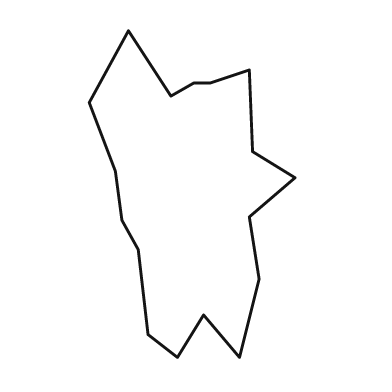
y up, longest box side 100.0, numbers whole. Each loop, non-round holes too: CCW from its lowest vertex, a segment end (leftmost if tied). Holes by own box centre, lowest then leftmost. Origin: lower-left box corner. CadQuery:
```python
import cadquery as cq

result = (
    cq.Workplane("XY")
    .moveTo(27.0, 0.0)
    .lineTo(35.0, 13.0)
    .lineTo(46.0, 0.0)
    .lineTo(52.0, 24.0)
    .lineTo(49.0, 43.0)
    .lineTo(63.0, 55.0)
    .lineTo(50.0, 63.0)
    .lineTo(49.0, 88.0)
    .lineTo(37.0, 84.0)
    .lineTo(32.0, 84.0)
    .lineTo(25.0, 80.0)
    .lineTo(12.0, 100.0)
    .lineTo(0.0, 78.0)
    .lineTo(8.0, 57.0)
    .lineTo(10.0, 42.0)
    .lineTo(15.0, 33.0)
    .lineTo(18.0, 7.0)
    .close()
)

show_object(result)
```